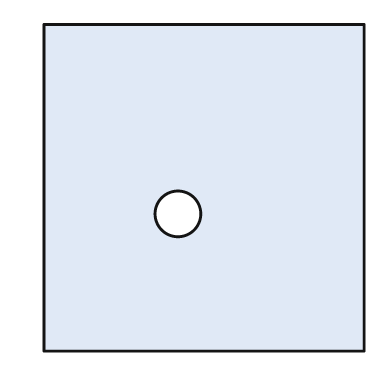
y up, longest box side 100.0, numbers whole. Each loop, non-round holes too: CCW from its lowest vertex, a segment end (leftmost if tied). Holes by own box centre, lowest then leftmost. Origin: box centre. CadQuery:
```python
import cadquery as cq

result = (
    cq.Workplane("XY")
    .moveTo(-49.0, -50.0)
    .lineTo(49.0, -50.0)
    .lineTo(49.0, 50.0)
    .lineTo(-49.0, 50.0)
    .close()
    .moveTo(-8.0, -8.0)
    .circle(7.0)
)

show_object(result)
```